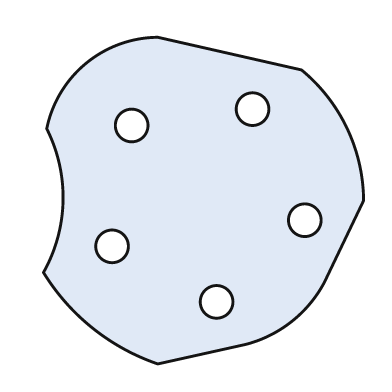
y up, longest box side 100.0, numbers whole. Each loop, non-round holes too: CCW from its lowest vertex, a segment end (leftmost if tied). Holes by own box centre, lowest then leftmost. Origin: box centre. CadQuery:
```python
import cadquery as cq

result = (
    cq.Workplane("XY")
    .moveTo(-14.0, -50.0)
    .lineTo(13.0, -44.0)
    .threePointArc((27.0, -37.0), (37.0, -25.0))
    .lineTo(49.0, 0.0)
    .threePointArc((44.0, 22.0), (30.0, 40.0))
    .lineTo(-14.0, 50.0)
    .threePointArc((-36.0, 42.0), (-48.0, 22.0))
    .threePointArc((-43.0, 0.0), (-49.0, -22.0))
    .threePointArc((-34.0, -39.0), (-14.0, -50.0))
    .close()
    .moveTo(4.0, -31.0)
    .circle(5.0)
    .moveTo(-28.0, -14.0)
    .circle(5.0)
    .moveTo(31.0, -6.0)
    .circle(5.0)
    .moveTo(-22.0, 23.0)
    .circle(5.0)
    .moveTo(15.0, 28.0)
    .circle(5.0)
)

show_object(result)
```